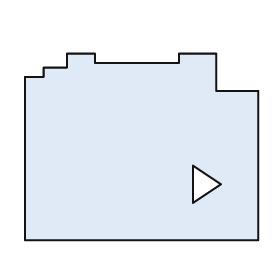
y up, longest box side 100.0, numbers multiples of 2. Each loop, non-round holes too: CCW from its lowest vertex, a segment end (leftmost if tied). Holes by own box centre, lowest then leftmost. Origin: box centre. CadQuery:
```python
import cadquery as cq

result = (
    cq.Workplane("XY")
    .moveTo(-50.0, -40.0)
    .lineTo(50.0, -40.0)
    .lineTo(50.0, 24.0)
    .lineTo(32.0, 24.0)
    .lineTo(32.0, 40.0)
    .lineTo(16.0, 40.0)
    .lineTo(16.0, 36.0)
    .lineTo(-20.0, 36.0)
    .lineTo(-20.0, 40.0)
    .lineTo(-32.0, 40.0)
    .lineTo(-32.0, 34.0)
    .lineTo(-42.0, 34.0)
    .lineTo(-42.0, 30.0)
    .lineTo(-50.0, 30.0)
    .close()
    .moveTo(22.0, -24.0)
    .lineTo(34.0, -16.0)
    .lineTo(22.0, -8.0)
    .close()
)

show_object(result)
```